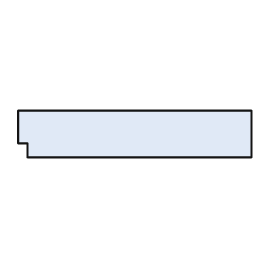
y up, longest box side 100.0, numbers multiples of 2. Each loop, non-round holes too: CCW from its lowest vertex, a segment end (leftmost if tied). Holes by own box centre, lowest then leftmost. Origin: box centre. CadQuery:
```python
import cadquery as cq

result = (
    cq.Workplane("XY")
    .moveTo(-46.0, -10.0)
    .lineTo(50.0, -10.0)
    .lineTo(50.0, 10.0)
    .lineTo(-50.0, 10.0)
    .lineTo(-50.0, -4.0)
    .lineTo(-46.0, -4.0)
    .close()
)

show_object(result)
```